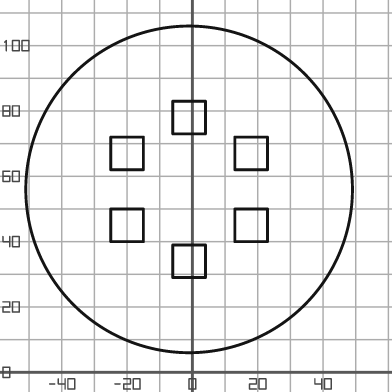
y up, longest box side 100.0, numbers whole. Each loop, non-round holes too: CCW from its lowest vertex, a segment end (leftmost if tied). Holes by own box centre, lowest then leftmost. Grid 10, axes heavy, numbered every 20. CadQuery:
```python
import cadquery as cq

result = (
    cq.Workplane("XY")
    .moveTo(-1.0, 56.0)
    .circle(50.0)
    .moveTo(-6.0, 29.0)
    .lineTo(4.0, 29.0)
    .lineTo(4.0, 39.0)
    .lineTo(-6.0, 39.0)
    .close()
    .moveTo(-25.0, 40.0)
    .lineTo(-15.0, 40.0)
    .lineTo(-15.0, 50.0)
    .lineTo(-25.0, 50.0)
    .close()
    .moveTo(13.0, 40.0)
    .lineTo(23.0, 40.0)
    .lineTo(23.0, 50.0)
    .lineTo(13.0, 50.0)
    .close()
    .moveTo(-25.0, 62.0)
    .lineTo(-15.0, 62.0)
    .lineTo(-15.0, 72.0)
    .lineTo(-25.0, 72.0)
    .close()
    .moveTo(13.0, 62.0)
    .lineTo(23.0, 62.0)
    .lineTo(23.0, 72.0)
    .lineTo(13.0, 72.0)
    .close()
    .moveTo(-6.0, 73.0)
    .lineTo(4.0, 73.0)
    .lineTo(4.0, 83.0)
    .lineTo(-6.0, 83.0)
    .close()
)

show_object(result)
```